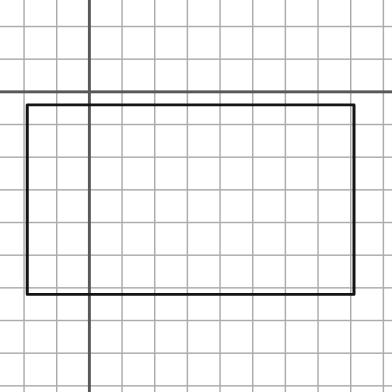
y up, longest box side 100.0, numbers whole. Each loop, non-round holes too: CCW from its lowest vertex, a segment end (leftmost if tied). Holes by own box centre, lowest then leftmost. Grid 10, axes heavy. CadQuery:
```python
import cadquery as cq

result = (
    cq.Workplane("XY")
    .moveTo(-19.0, -62.0)
    .lineTo(81.0, -62.0)
    .lineTo(81.0, -4.0)
    .lineTo(-19.0, -4.0)
    .close()
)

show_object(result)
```